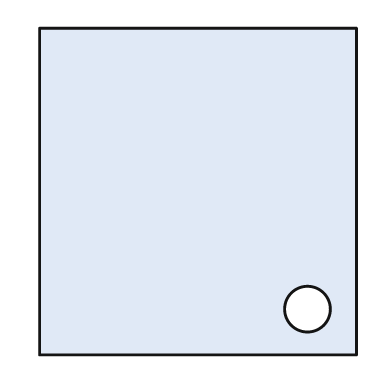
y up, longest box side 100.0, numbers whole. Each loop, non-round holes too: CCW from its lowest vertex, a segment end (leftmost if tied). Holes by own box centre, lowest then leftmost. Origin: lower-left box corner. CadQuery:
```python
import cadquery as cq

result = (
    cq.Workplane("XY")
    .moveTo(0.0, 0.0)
    .lineTo(97.0, 0.0)
    .lineTo(97.0, 100.0)
    .lineTo(0.0, 100.0)
    .close()
    .moveTo(82.0, 14.0)
    .circle(7.0)
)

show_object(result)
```